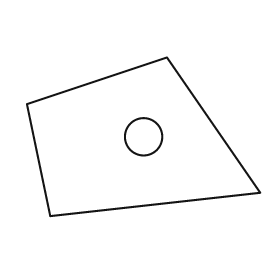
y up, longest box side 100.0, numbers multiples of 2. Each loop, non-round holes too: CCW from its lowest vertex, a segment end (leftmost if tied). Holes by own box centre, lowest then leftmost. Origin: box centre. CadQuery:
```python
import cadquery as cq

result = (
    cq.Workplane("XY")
    .moveTo(-40.0, -34.0)
    .lineTo(50.0, -24.0)
    .lineTo(10.0, 34.0)
    .lineTo(-50.0, 14.0)
    .close()
    .moveTo(0.0, 0.0)
    .circle(8.0)
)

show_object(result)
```